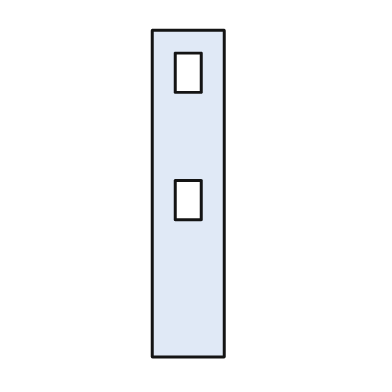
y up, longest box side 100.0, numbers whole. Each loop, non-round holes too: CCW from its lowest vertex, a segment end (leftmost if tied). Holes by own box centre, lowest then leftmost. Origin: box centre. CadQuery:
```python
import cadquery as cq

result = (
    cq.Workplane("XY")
    .moveTo(-11.0, -50.0)
    .lineTo(11.0, -50.0)
    .lineTo(11.0, 50.0)
    .lineTo(-11.0, 50.0)
    .close()
    .moveTo(-4.0, -8.0)
    .lineTo(4.0, -8.0)
    .lineTo(4.0, 4.0)
    .lineTo(-4.0, 4.0)
    .close()
    .moveTo(-4.0, 31.0)
    .lineTo(4.0, 31.0)
    .lineTo(4.0, 43.0)
    .lineTo(-4.0, 43.0)
    .close()
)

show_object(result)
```